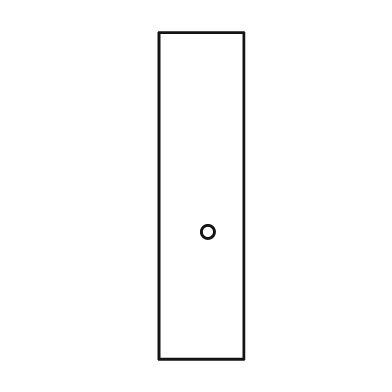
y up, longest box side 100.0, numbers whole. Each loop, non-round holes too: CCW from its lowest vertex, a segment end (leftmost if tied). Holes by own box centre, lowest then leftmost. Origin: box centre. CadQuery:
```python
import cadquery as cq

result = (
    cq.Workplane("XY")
    .moveTo(-13.0, -50.0)
    .lineTo(13.0, -50.0)
    .lineTo(13.0, 50.0)
    .lineTo(-13.0, 50.0)
    .close()
    .moveTo(2.0, -11.0)
    .circle(2.0)
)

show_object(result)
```